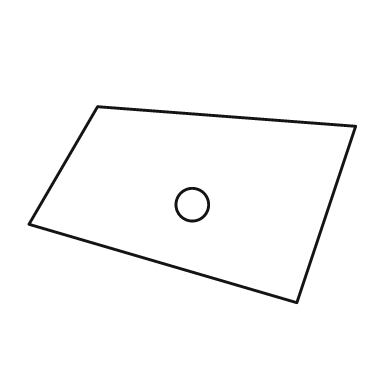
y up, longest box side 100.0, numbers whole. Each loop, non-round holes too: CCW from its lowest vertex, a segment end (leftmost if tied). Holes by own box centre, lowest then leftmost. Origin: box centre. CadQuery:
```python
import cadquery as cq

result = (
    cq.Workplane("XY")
    .moveTo(32.0, -30.0)
    .lineTo(50.0, 24.0)
    .lineTo(-29.0, 30.0)
    .lineTo(-50.0, -6.0)
    .close()
    .moveTo(0.0, 0.0)
    .circle(5.0)
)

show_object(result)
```